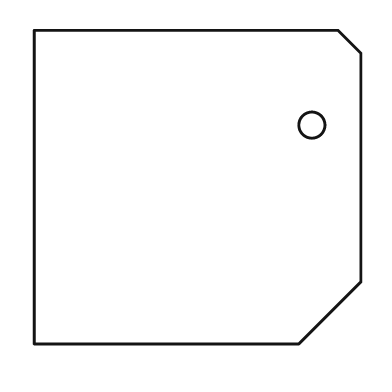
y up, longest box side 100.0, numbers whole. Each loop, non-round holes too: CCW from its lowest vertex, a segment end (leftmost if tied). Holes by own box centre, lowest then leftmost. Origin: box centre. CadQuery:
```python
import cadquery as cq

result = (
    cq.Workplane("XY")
    .moveTo(-50.0, -48.0)
    .lineTo(31.0, -48.0)
    .lineTo(50.0, -29.0)
    .lineTo(50.0, 41.0)
    .lineTo(43.0, 48.0)
    .lineTo(-50.0, 48.0)
    .close()
    .moveTo(35.0, 19.0)
    .circle(4.0)
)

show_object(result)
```